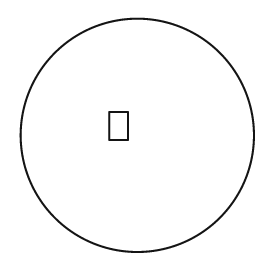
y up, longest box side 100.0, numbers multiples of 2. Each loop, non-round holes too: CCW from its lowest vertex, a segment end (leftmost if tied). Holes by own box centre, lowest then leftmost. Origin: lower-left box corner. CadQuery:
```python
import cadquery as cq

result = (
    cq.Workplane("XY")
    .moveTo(50.0, 50.0)
    .circle(50.0)
    .moveTo(38.0, 48.0)
    .lineTo(46.0, 48.0)
    .lineTo(46.0, 60.0)
    .lineTo(38.0, 60.0)
    .close()
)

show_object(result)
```